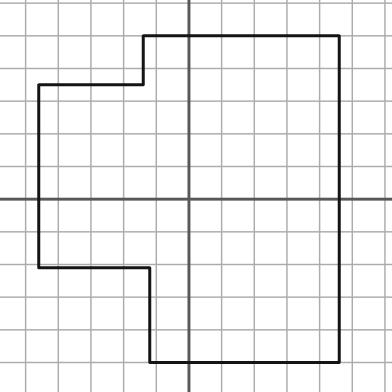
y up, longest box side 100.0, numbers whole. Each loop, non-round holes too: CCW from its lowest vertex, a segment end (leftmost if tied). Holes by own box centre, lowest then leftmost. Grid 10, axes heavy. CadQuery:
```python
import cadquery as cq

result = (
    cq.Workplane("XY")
    .moveTo(-12.0, -50.0)
    .lineTo(46.0, -50.0)
    .lineTo(46.0, 50.0)
    .lineTo(-14.0, 50.0)
    .lineTo(-14.0, 35.0)
    .lineTo(-46.0, 35.0)
    .lineTo(-46.0, -21.0)
    .lineTo(-12.0, -21.0)
    .close()
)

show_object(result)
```